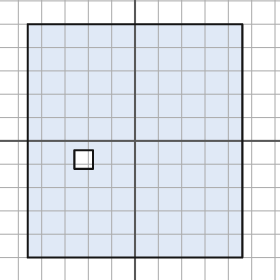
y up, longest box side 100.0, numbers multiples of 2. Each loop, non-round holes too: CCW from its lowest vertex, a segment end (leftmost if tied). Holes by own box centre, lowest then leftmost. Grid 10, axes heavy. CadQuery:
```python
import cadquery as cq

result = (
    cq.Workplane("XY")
    .moveTo(-46.0, -50.0)
    .lineTo(46.0, -50.0)
    .lineTo(46.0, 50.0)
    .lineTo(-46.0, 50.0)
    .close()
    .moveTo(-26.0, -12.0)
    .lineTo(-18.0, -12.0)
    .lineTo(-18.0, -4.0)
    .lineTo(-26.0, -4.0)
    .close()
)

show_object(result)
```